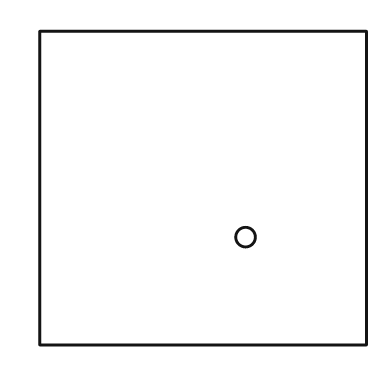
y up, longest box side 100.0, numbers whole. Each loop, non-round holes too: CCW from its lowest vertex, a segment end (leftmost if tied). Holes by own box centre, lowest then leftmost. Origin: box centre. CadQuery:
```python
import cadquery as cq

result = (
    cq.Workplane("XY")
    .moveTo(-50.0, -48.0)
    .lineTo(50.0, -48.0)
    .lineTo(50.0, 48.0)
    .lineTo(-50.0, 48.0)
    .close()
    .moveTo(13.0, -15.0)
    .circle(3.0)
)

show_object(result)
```